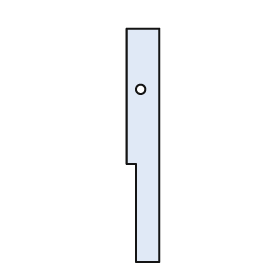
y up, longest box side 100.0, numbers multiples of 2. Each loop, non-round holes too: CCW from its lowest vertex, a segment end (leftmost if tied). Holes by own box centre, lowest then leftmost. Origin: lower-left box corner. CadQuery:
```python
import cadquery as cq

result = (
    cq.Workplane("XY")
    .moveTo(4.0, 0.0)
    .lineTo(14.0, 0.0)
    .lineTo(14.0, 100.0)
    .lineTo(0.0, 100.0)
    .lineTo(0.0, 42.0)
    .lineTo(4.0, 42.0)
    .close()
    .moveTo(6.0, 74.0)
    .circle(2.0)
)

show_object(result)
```